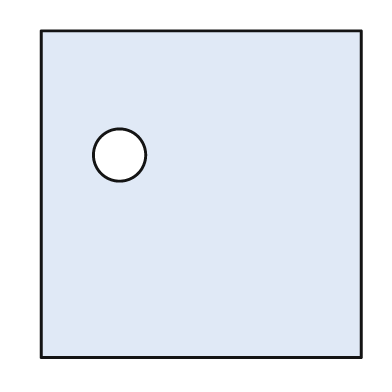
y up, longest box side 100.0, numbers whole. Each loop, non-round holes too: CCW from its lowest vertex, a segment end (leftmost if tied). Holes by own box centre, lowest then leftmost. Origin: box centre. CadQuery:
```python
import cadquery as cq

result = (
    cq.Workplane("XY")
    .moveTo(-49.0, -50.0)
    .lineTo(49.0, -50.0)
    .lineTo(49.0, 50.0)
    .lineTo(-49.0, 50.0)
    .close()
    .moveTo(-25.0, 12.0)
    .circle(8.0)
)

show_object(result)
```